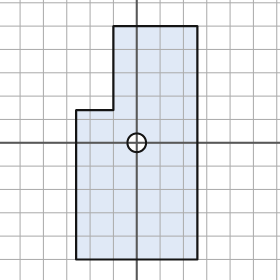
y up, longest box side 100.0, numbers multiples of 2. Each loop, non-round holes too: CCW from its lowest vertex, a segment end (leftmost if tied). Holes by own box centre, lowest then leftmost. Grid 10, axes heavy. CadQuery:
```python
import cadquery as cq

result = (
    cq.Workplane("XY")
    .moveTo(-26.0, -50.0)
    .lineTo(26.0, -50.0)
    .lineTo(26.0, 50.0)
    .lineTo(-10.0, 50.0)
    .lineTo(-10.0, 14.0)
    .lineTo(-26.0, 14.0)
    .close()
    .moveTo(0.0, 0.0)
    .circle(4.0)
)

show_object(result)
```